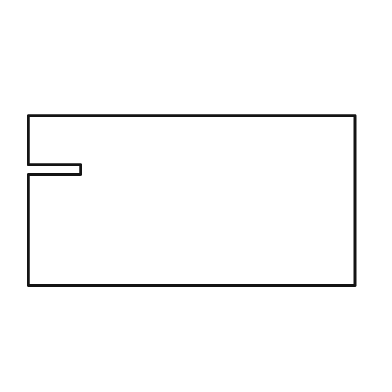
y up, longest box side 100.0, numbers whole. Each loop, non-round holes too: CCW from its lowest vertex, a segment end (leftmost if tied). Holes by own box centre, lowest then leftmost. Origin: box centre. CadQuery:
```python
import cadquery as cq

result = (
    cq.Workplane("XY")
    .moveTo(-50.0, -26.0)
    .lineTo(50.0, -26.0)
    .lineTo(50.0, 26.0)
    .lineTo(-50.0, 26.0)
    .lineTo(-50.0, 11.0)
    .lineTo(-34.0, 11.0)
    .lineTo(-34.0, 8.0)
    .lineTo(-50.0, 8.0)
    .close()
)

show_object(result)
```